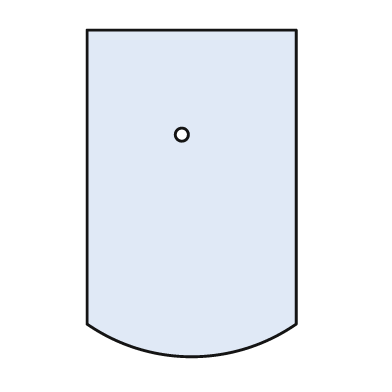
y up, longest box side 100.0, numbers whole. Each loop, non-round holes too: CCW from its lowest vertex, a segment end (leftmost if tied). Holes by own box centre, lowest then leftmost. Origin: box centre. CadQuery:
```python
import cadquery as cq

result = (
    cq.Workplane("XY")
    .moveTo(-32.0, -40.0)
    .threePointArc((0.0, -50.0), (32.0, -40.0))
    .lineTo(32.0, 50.0)
    .lineTo(-32.0, 50.0)
    .close()
    .moveTo(-3.0, 18.0)
    .circle(2.0)
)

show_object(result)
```